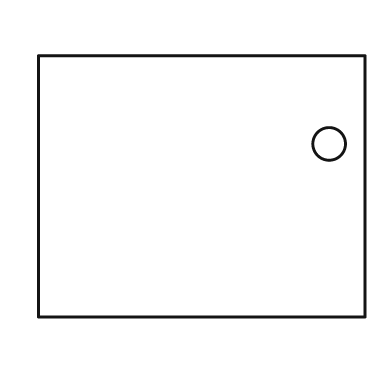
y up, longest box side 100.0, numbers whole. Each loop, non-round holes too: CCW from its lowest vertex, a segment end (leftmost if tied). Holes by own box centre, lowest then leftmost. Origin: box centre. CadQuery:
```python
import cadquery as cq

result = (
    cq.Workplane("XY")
    .moveTo(-50.0, -40.0)
    .lineTo(50.0, -40.0)
    .lineTo(50.0, 40.0)
    .lineTo(-50.0, 40.0)
    .close()
    .moveTo(39.0, 13.0)
    .circle(5.0)
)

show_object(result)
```